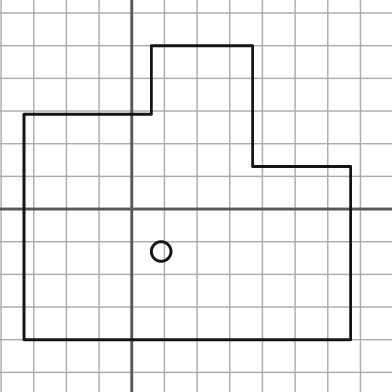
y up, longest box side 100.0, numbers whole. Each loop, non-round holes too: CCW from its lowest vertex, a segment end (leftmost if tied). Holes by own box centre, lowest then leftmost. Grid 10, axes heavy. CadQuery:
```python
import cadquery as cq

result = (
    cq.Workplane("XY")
    .moveTo(-33.0, -40.0)
    .lineTo(67.0, -40.0)
    .lineTo(67.0, 13.0)
    .lineTo(37.0, 13.0)
    .lineTo(37.0, 50.0)
    .lineTo(6.0, 50.0)
    .lineTo(6.0, 29.0)
    .lineTo(-33.0, 29.0)
    .close()
    .moveTo(9.0, -13.0)
    .circle(3.0)
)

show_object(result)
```